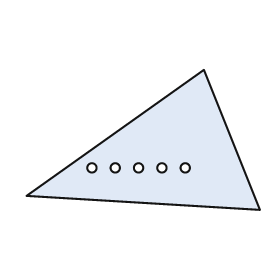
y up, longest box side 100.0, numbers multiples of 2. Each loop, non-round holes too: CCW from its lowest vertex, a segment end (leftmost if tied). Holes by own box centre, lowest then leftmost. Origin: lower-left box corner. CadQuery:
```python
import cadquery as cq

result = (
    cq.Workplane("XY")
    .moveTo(100.0, 0.0)
    .lineTo(76.0, 60.0)
    .lineTo(0.0, 6.0)
    .close()
    .moveTo(28.0, 18.0)
    .circle(2.0)
    .moveTo(38.0, 18.0)
    .circle(2.0)
    .moveTo(48.0, 18.0)
    .circle(2.0)
    .moveTo(58.0, 18.0)
    .circle(2.0)
    .moveTo(68.0, 18.0)
    .circle(2.0)
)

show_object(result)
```